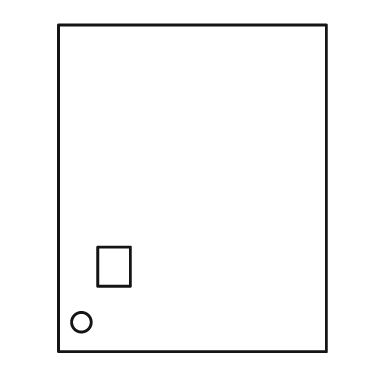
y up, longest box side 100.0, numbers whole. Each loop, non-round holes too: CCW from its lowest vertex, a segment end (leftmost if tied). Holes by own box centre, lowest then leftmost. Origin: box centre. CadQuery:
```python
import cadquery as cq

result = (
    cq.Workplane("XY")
    .moveTo(-41.0, -50.0)
    .lineTo(41.0, -50.0)
    .lineTo(41.0, 50.0)
    .lineTo(-41.0, 50.0)
    .close()
    .moveTo(-34.0, -41.0)
    .circle(3.0)
    .moveTo(-29.0, -30.0)
    .lineTo(-19.0, -30.0)
    .lineTo(-19.0, -18.0)
    .lineTo(-29.0, -18.0)
    .close()
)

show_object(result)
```